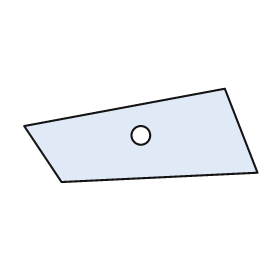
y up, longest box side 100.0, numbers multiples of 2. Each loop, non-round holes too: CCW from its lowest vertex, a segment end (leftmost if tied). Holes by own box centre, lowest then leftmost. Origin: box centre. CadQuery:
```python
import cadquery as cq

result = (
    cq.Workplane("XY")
    .moveTo(-34.0, -20.0)
    .lineTo(50.0, -16.0)
    .lineTo(36.0, 20.0)
    .lineTo(-50.0, 4.0)
    .close()
    .moveTo(0.0, 0.0)
    .circle(4.0)
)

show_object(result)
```